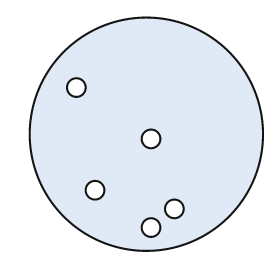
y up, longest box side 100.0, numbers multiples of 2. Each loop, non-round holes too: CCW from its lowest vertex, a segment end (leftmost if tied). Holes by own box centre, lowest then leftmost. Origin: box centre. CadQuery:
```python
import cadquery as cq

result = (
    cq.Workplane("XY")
    .moveTo(0.0, 0.0)
    .circle(50.0)
    .moveTo(2.0, -40.0)
    .circle(4.0)
    .moveTo(12.0, -32.0)
    .circle(4.0)
    .moveTo(-22.0, -24.0)
    .circle(4.0)
    .moveTo(2.0, -2.0)
    .circle(4.0)
    .moveTo(-30.0, 20.0)
    .circle(4.0)
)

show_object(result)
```